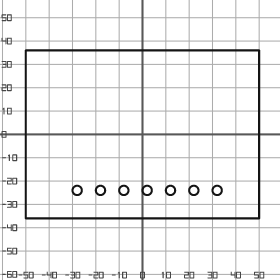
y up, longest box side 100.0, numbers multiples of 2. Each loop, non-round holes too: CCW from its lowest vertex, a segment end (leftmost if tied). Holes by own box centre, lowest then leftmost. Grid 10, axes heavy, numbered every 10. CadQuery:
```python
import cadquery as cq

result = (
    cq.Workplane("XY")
    .moveTo(-50.0, -36.0)
    .lineTo(50.0, -36.0)
    .lineTo(50.0, 36.0)
    .lineTo(-50.0, 36.0)
    .close()
    .moveTo(-28.0, -24.0)
    .circle(2.0)
    .moveTo(-18.0, -24.0)
    .circle(2.0)
    .moveTo(-8.0, -24.0)
    .circle(2.0)
    .moveTo(2.0, -24.0)
    .circle(2.0)
    .moveTo(12.0, -24.0)
    .circle(2.0)
    .moveTo(22.0, -24.0)
    .circle(2.0)
    .moveTo(32.0, -24.0)
    .circle(2.0)
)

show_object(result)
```